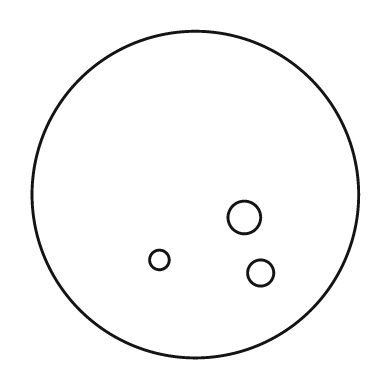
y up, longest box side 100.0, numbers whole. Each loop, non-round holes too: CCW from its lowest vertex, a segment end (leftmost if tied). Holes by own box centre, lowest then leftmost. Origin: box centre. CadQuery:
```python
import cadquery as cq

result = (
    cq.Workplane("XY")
    .moveTo(0.0, 0.0)
    .circle(50.0)
    .moveTo(20.0, -24.0)
    .circle(4.0)
    .moveTo(-11.0, -20.0)
    .circle(3.0)
    .moveTo(15.0, -7.0)
    .circle(5.0)
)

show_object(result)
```